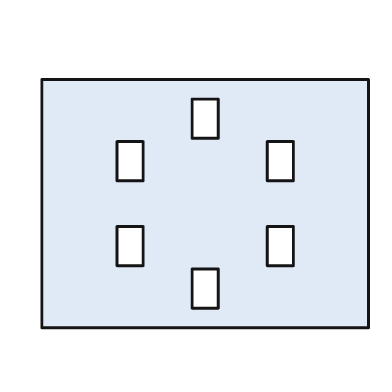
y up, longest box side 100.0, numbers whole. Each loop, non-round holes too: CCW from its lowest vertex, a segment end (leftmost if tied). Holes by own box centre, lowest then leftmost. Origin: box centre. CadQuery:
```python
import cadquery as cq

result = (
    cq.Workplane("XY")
    .moveTo(-50.0, -38.0)
    .lineTo(50.0, -38.0)
    .lineTo(50.0, 38.0)
    .lineTo(-50.0, 38.0)
    .close()
    .moveTo(-4.0, -32.0)
    .lineTo(4.0, -32.0)
    .lineTo(4.0, -20.0)
    .lineTo(-4.0, -20.0)
    .close()
    .moveTo(-27.0, -19.0)
    .lineTo(-19.0, -19.0)
    .lineTo(-19.0, -7.0)
    .lineTo(-27.0, -7.0)
    .close()
    .moveTo(19.0, -19.0)
    .lineTo(27.0, -19.0)
    .lineTo(27.0, -7.0)
    .lineTo(19.0, -7.0)
    .close()
    .moveTo(-27.0, 7.0)
    .lineTo(-19.0, 7.0)
    .lineTo(-19.0, 19.0)
    .lineTo(-27.0, 19.0)
    .close()
    .moveTo(19.0, 7.0)
    .lineTo(27.0, 7.0)
    .lineTo(27.0, 19.0)
    .lineTo(19.0, 19.0)
    .close()
    .moveTo(-4.0, 20.0)
    .lineTo(4.0, 20.0)
    .lineTo(4.0, 32.0)
    .lineTo(-4.0, 32.0)
    .close()
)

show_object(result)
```